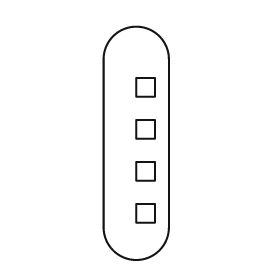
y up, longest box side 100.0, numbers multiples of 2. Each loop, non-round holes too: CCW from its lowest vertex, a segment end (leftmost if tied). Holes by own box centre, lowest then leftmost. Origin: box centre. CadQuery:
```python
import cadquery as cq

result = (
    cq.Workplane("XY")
    .moveTo(-14.0, -36.0)
    .threePointArc((0.0, -50.0), (14.0, -36.0))
    .lineTo(14.0, 36.0)
    .threePointArc((0.0, 50.0), (-14.0, 36.0))
    .close()
    .moveTo(0.0, -34.0)
    .lineTo(8.0, -34.0)
    .lineTo(8.0, -26.0)
    .lineTo(0.0, -26.0)
    .close()
    .moveTo(0.0, -16.0)
    .lineTo(8.0, -16.0)
    .lineTo(8.0, -8.0)
    .lineTo(0.0, -8.0)
    .close()
    .moveTo(0.0, 2.0)
    .lineTo(8.0, 2.0)
    .lineTo(8.0, 10.0)
    .lineTo(0.0, 10.0)
    .close()
    .moveTo(0.0, 20.0)
    .lineTo(8.0, 20.0)
    .lineTo(8.0, 28.0)
    .lineTo(0.0, 28.0)
    .close()
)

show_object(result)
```